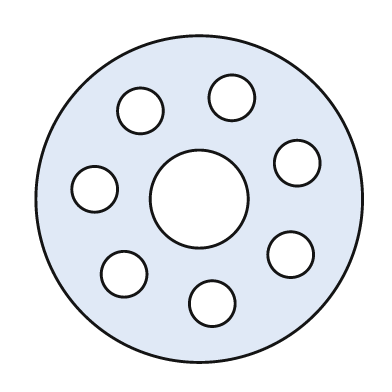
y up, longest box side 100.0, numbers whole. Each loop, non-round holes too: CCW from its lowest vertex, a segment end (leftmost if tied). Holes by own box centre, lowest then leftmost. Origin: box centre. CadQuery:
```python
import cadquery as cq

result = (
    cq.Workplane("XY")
    .moveTo(0.0, 0.0)
    .circle(50.0)
    .moveTo(4.0, -32.0)
    .circle(7.0)
    .moveTo(-23.0, -23.0)
    .circle(7.0)
    .moveTo(28.0, -17.0)
    .circle(7.0)
    .moveTo(0.0, 0.0)
    .circle(15.0)
    .moveTo(-32.0, 3.0)
    .circle(7.0)
    .moveTo(30.0, 11.0)
    .circle(7.0)
    .moveTo(-18.0, 27.0)
    .circle(7.0)
    .moveTo(10.0, 31.0)
    .circle(7.0)
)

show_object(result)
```